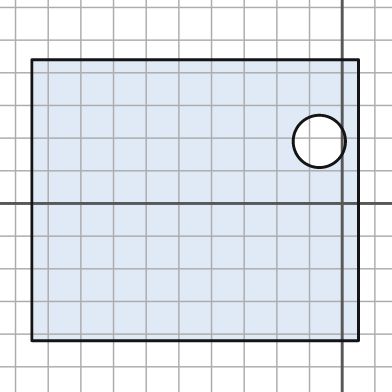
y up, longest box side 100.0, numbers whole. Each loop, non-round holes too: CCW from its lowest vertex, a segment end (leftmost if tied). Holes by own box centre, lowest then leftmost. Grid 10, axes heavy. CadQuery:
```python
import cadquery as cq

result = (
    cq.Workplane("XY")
    .moveTo(-95.0, -42.0)
    .lineTo(5.0, -42.0)
    .lineTo(5.0, 44.0)
    .lineTo(-95.0, 44.0)
    .close()
    .moveTo(-7.0, 19.0)
    .circle(8.0)
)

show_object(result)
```